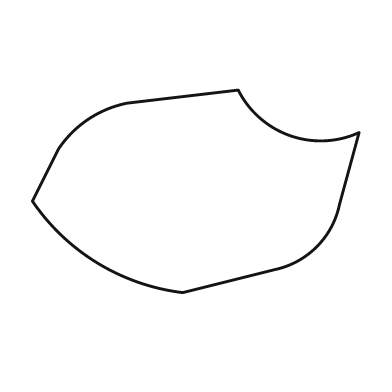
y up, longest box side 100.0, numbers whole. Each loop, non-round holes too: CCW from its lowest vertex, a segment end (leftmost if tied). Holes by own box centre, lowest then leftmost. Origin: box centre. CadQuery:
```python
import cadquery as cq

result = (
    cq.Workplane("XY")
    .moveTo(-4.0, -31.0)
    .lineTo(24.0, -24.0)
    .threePointArc((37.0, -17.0), (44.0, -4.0))
    .lineTo(50.0, 18.0)
    .threePointArc((29.0, 17.0), (13.0, 31.0))
    .lineTo(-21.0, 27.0)
    .threePointArc((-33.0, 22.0), (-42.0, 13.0))
    .lineTo(-50.0, -3.0)
    .threePointArc((-30.0, -22.0), (-4.0, -31.0))
    .close()
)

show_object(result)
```